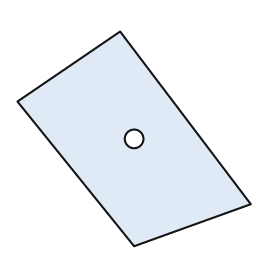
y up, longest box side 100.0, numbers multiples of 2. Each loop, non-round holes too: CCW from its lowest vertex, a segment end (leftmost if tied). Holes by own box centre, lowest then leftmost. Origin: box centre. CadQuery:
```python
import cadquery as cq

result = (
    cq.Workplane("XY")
    .moveTo(0.0, -46.0)
    .lineTo(50.0, -28.0)
    .lineTo(-6.0, 46.0)
    .lineTo(-50.0, 16.0)
    .close()
    .moveTo(0.0, 0.0)
    .circle(4.0)
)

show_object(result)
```